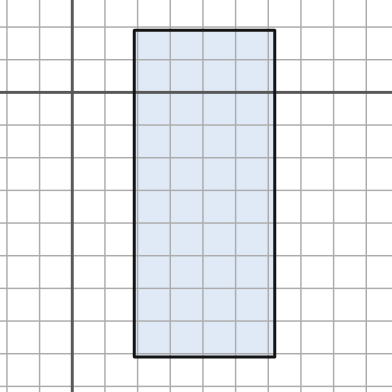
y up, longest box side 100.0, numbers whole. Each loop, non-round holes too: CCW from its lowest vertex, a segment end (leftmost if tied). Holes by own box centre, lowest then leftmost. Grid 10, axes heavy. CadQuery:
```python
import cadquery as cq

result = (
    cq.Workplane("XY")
    .moveTo(19.0, -81.0)
    .lineTo(62.0, -81.0)
    .lineTo(62.0, 19.0)
    .lineTo(19.0, 19.0)
    .close()
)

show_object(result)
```